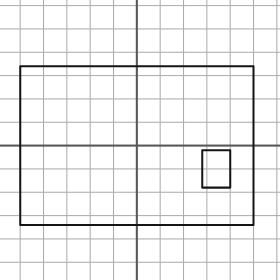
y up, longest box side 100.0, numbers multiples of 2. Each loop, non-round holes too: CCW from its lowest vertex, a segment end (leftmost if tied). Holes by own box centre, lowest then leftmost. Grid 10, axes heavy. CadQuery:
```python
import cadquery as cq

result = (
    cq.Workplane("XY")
    .moveTo(-50.0, -34.0)
    .lineTo(50.0, -34.0)
    .lineTo(50.0, 34.0)
    .lineTo(-50.0, 34.0)
    .close()
    .moveTo(28.0, -18.0)
    .lineTo(40.0, -18.0)
    .lineTo(40.0, -2.0)
    .lineTo(28.0, -2.0)
    .close()
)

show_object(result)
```